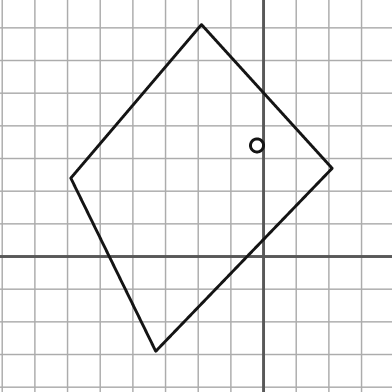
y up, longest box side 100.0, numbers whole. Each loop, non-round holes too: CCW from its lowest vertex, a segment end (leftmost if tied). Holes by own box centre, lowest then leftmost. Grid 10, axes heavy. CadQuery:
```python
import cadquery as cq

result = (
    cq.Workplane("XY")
    .moveTo(-33.0, -29.0)
    .lineTo(21.0, 27.0)
    .lineTo(-19.0, 71.0)
    .lineTo(-59.0, 24.0)
    .close()
    .moveTo(-2.0, 34.0)
    .circle(2.0)
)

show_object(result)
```